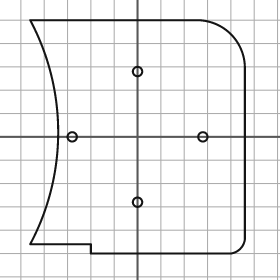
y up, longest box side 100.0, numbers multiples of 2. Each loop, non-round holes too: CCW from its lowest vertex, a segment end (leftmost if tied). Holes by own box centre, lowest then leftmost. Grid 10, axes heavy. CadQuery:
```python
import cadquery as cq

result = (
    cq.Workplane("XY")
    .moveTo(-20.0, -50.0)
    .lineTo(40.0, -50.0)
    .threePointArc((44.0, -48.0), (46.0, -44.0))
    .lineTo(46.0, 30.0)
    .threePointArc((40.0, 44.0), (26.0, 50.0))
    .lineTo(-46.0, 50.0)
    .threePointArc((-34.0, 2.0), (-46.0, -46.0))
    .lineTo(-20.0, -46.0)
    .close()
    .moveTo(0.0, -28.0)
    .circle(2.0)
    .moveTo(-28.0, 0.0)
    .circle(2.0)
    .moveTo(28.0, 0.0)
    .circle(2.0)
    .moveTo(0.0, 28.0)
    .circle(2.0)
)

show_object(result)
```